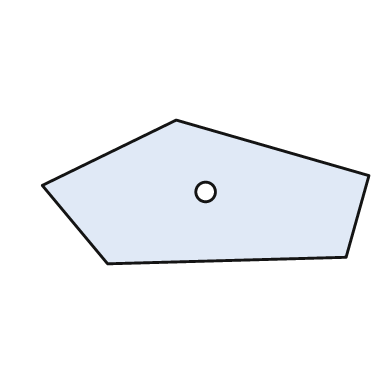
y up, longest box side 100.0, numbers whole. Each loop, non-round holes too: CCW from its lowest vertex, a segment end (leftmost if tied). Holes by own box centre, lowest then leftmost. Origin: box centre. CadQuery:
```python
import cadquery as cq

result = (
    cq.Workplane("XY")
    .moveTo(-30.0, -22.0)
    .lineTo(43.0, -20.0)
    .lineTo(50.0, 5.0)
    .lineTo(-9.0, 22.0)
    .lineTo(-50.0, 2.0)
    .close()
    .moveTo(0.0, 0.0)
    .circle(3.0)
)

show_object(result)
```